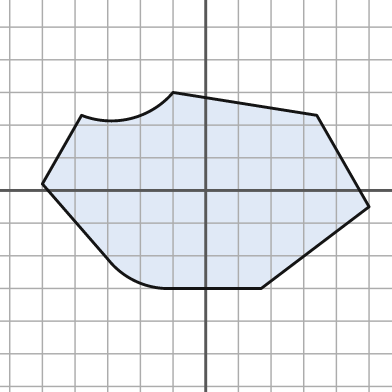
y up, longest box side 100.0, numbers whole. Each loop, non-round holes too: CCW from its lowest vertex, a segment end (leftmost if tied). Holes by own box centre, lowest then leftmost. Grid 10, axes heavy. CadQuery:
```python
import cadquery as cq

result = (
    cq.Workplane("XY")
    .moveTo(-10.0, -30.0)
    .lineTo(17.0, -30.0)
    .lineTo(50.0, -5.0)
    .lineTo(34.0, 23.0)
    .lineTo(-10.0, 30.0)
    .threePointArc((-23.0, 22.0), (-38.0, 23.0))
    .lineTo(-50.0, 2.0)
    .lineTo(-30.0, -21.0)
    .threePointArc((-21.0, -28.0), (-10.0, -30.0))
    .close()
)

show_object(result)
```